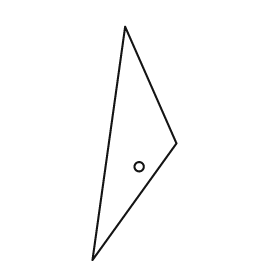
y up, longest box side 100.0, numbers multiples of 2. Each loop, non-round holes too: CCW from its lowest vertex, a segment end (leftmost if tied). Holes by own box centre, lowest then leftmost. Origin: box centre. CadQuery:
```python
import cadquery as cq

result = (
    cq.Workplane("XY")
    .moveTo(-18.0, -50.0)
    .lineTo(18.0, 0.0)
    .lineTo(-4.0, 50.0)
    .close()
    .moveTo(2.0, -10.0)
    .circle(2.0)
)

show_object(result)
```